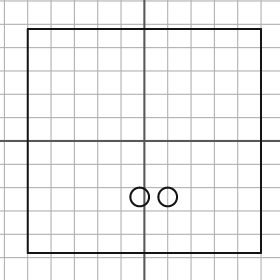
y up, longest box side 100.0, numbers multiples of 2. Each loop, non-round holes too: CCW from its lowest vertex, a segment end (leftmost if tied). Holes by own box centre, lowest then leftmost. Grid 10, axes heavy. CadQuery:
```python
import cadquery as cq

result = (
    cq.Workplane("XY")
    .moveTo(-50.0, -48.0)
    .lineTo(50.0, -48.0)
    .lineTo(50.0, 48.0)
    .lineTo(-50.0, 48.0)
    .close()
    .moveTo(-2.0, -24.0)
    .circle(4.0)
    .moveTo(10.0, -24.0)
    .circle(4.0)
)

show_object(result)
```